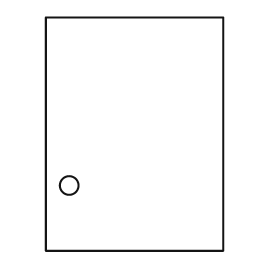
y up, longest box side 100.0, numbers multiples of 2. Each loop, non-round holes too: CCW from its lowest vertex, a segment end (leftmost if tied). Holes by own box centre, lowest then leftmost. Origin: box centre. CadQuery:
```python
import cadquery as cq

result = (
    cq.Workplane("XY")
    .moveTo(-38.0, -50.0)
    .lineTo(38.0, -50.0)
    .lineTo(38.0, 50.0)
    .lineTo(-38.0, 50.0)
    .close()
    .moveTo(-28.0, -22.0)
    .circle(4.0)
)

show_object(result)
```